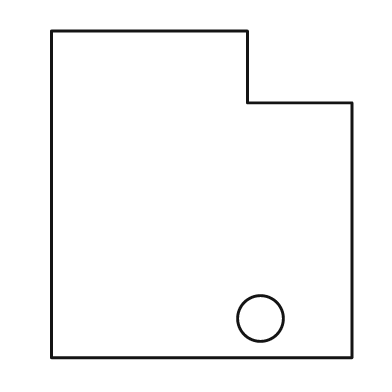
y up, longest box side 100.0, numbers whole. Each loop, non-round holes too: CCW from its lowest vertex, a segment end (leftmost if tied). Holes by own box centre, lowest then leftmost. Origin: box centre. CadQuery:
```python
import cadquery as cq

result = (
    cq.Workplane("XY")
    .moveTo(-46.0, -50.0)
    .lineTo(46.0, -50.0)
    .lineTo(46.0, 28.0)
    .lineTo(14.0, 28.0)
    .lineTo(14.0, 50.0)
    .lineTo(-46.0, 50.0)
    .close()
    .moveTo(18.0, -38.0)
    .circle(7.0)
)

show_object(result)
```